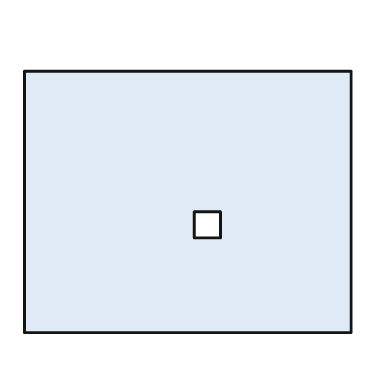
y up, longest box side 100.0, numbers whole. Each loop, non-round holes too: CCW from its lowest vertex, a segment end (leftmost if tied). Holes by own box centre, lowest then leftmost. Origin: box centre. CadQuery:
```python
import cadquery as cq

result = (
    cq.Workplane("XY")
    .moveTo(-50.0, -40.0)
    .lineTo(50.0, -40.0)
    .lineTo(50.0, 40.0)
    .lineTo(-50.0, 40.0)
    .close()
    .moveTo(2.0, -11.0)
    .lineTo(10.0, -11.0)
    .lineTo(10.0, -3.0)
    .lineTo(2.0, -3.0)
    .close()
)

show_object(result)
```